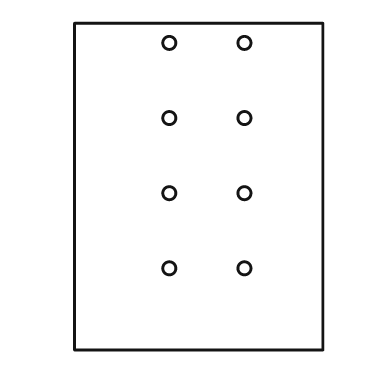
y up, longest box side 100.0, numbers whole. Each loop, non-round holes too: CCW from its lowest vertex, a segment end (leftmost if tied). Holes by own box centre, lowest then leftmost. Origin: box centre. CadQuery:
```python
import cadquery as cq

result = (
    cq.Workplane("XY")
    .moveTo(-38.0, -50.0)
    .lineTo(38.0, -50.0)
    .lineTo(38.0, 50.0)
    .lineTo(-38.0, 50.0)
    .close()
    .moveTo(-9.0, -25.0)
    .circle(2.0)
    .moveTo(14.0, -25.0)
    .circle(2.0)
    .moveTo(-9.0, -2.0)
    .circle(2.0)
    .moveTo(14.0, -2.0)
    .circle(2.0)
    .moveTo(-9.0, 21.0)
    .circle(2.0)
    .moveTo(14.0, 21.0)
    .circle(2.0)
    .moveTo(-9.0, 44.0)
    .circle(2.0)
    .moveTo(14.0, 44.0)
    .circle(2.0)
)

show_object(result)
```